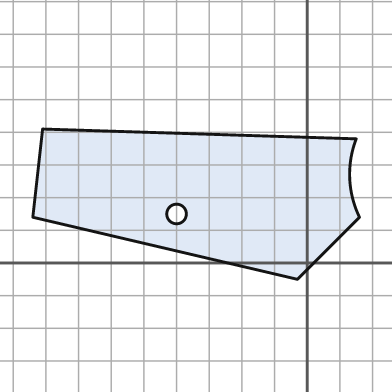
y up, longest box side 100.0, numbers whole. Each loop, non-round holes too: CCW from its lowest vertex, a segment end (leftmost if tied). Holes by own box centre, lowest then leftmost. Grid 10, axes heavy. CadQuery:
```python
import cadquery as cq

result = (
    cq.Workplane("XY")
    .moveTo(-3.0, -5.0)
    .lineTo(16.0, 14.0)
    .threePointArc((13.0, 26.0), (15.0, 38.0))
    .lineTo(-81.0, 41.0)
    .lineTo(-84.0, 14.0)
    .close()
    .moveTo(-40.0, 15.0)
    .circle(3.0)
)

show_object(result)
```